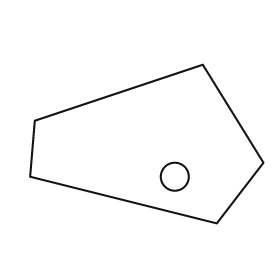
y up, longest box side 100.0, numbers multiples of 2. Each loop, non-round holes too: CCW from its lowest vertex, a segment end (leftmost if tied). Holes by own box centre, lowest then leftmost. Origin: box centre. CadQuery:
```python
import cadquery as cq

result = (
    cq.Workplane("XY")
    .moveTo(30.0, -34.0)
    .lineTo(50.0, -8.0)
    .lineTo(24.0, 34.0)
    .lineTo(-48.0, 10.0)
    .lineTo(-50.0, -14.0)
    .close()
    .moveTo(12.0, -14.0)
    .circle(6.0)
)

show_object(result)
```